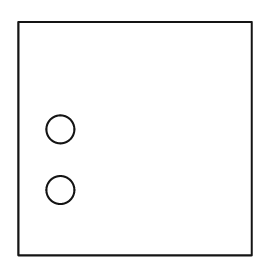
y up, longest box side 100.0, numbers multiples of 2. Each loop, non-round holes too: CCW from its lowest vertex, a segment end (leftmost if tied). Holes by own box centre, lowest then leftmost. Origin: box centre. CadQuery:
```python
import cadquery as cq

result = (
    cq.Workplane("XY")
    .moveTo(-50.0, -50.0)
    .lineTo(50.0, -50.0)
    .lineTo(50.0, 50.0)
    .lineTo(-50.0, 50.0)
    .close()
    .moveTo(-32.0, -22.0)
    .circle(6.0)
    .moveTo(-32.0, 4.0)
    .circle(6.0)
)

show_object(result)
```